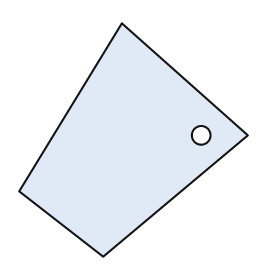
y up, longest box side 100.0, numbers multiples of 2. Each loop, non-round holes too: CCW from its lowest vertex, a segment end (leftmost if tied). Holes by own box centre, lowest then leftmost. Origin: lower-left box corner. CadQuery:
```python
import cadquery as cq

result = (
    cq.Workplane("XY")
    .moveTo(36.0, 0.0)
    .lineTo(98.0, 52.0)
    .lineTo(44.0, 100.0)
    .lineTo(0.0, 28.0)
    .close()
    .moveTo(78.0, 52.0)
    .circle(4.0)
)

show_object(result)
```